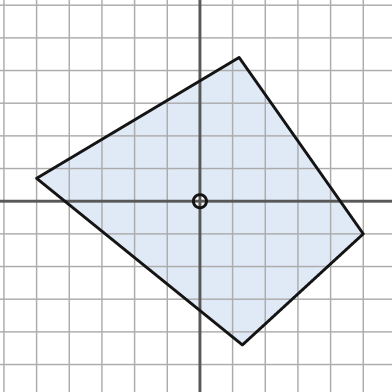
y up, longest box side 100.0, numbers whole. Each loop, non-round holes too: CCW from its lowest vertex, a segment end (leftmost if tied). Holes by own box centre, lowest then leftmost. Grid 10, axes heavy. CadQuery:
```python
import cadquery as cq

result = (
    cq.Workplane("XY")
    .moveTo(13.0, -44.0)
    .lineTo(50.0, -10.0)
    .lineTo(12.0, 44.0)
    .lineTo(-50.0, 7.0)
    .close()
    .moveTo(0.0, 0.0)
    .circle(2.0)
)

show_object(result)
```